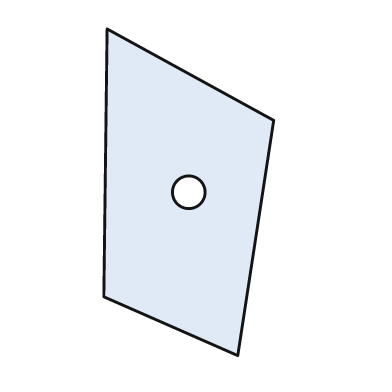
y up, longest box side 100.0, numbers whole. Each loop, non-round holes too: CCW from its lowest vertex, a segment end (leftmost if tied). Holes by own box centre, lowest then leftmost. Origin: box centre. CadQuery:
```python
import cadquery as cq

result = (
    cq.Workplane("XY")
    .moveTo(15.0, -50.0)
    .lineTo(26.0, 22.0)
    .lineTo(-25.0, 50.0)
    .lineTo(-26.0, -32.0)
    .close()
    .moveTo(0.0, 0.0)
    .circle(5.0)
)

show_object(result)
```